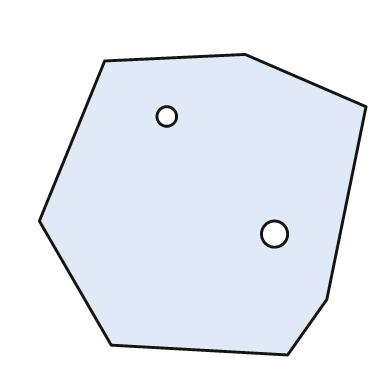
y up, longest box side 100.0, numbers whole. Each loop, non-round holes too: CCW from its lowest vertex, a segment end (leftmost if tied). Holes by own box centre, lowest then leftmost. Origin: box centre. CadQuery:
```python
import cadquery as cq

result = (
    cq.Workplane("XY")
    .moveTo(26.0, -46.0)
    .lineTo(38.0, -29.0)
    .lineTo(50.0, 30.0)
    .lineTo(13.0, 46.0)
    .lineTo(-30.0, 44.0)
    .lineTo(-50.0, -5.0)
    .lineTo(-28.0, -43.0)
    .close()
    .moveTo(22.0, -9.0)
    .circle(4.0)
    .moveTo(-11.0, 27.0)
    .circle(3.0)
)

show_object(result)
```